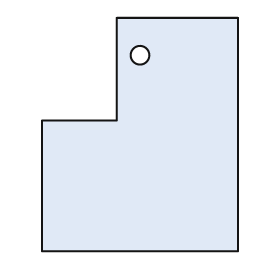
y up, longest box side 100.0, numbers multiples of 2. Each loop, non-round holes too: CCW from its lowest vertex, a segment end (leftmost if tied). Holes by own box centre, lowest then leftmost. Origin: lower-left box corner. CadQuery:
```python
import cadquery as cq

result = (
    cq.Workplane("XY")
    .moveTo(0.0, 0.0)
    .lineTo(84.0, 0.0)
    .lineTo(84.0, 100.0)
    .lineTo(32.0, 100.0)
    .lineTo(32.0, 56.0)
    .lineTo(0.0, 56.0)
    .close()
    .moveTo(42.0, 84.0)
    .circle(4.0)
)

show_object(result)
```